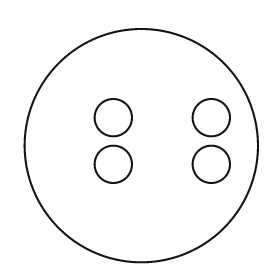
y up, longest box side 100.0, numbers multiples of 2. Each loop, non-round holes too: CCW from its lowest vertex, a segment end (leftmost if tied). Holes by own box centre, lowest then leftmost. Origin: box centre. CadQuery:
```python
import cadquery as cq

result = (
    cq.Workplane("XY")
    .moveTo(0.0, 0.0)
    .circle(50.0)
    .moveTo(-12.0, -8.0)
    .circle(8.0)
    .moveTo(30.0, -8.0)
    .circle(8.0)
    .moveTo(-12.0, 12.0)
    .circle(8.0)
    .moveTo(30.0, 12.0)
    .circle(8.0)
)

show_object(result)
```